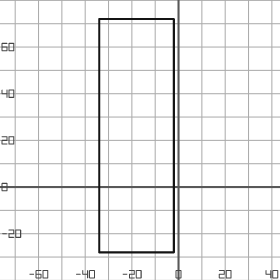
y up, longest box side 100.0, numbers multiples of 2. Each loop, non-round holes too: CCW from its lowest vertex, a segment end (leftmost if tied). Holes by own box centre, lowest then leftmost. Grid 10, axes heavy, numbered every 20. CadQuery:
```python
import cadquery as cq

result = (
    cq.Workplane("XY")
    .moveTo(-34.0, -28.0)
    .lineTo(-2.0, -28.0)
    .lineTo(-2.0, 72.0)
    .lineTo(-34.0, 72.0)
    .close()
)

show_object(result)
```